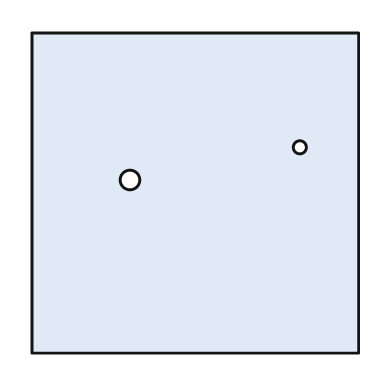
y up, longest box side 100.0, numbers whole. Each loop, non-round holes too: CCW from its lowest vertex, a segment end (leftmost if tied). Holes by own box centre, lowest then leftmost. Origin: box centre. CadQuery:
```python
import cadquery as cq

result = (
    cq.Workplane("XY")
    .moveTo(-50.0, -49.0)
    .lineTo(50.0, -49.0)
    .lineTo(50.0, 49.0)
    .lineTo(-50.0, 49.0)
    .close()
    .moveTo(-20.0, 4.0)
    .circle(3.0)
    .moveTo(32.0, 14.0)
    .circle(2.0)
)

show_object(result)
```